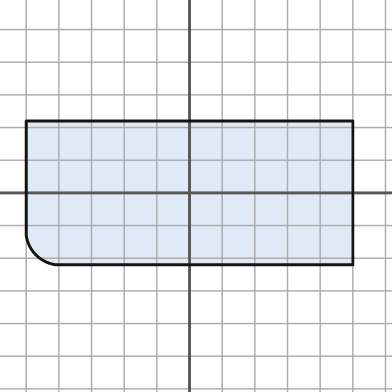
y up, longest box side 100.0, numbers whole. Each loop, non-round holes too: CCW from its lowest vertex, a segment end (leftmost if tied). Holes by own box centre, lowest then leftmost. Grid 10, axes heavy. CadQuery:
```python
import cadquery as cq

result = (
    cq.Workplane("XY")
    .moveTo(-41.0, -22.0)
    .lineTo(50.0, -22.0)
    .lineTo(50.0, 22.0)
    .lineTo(-50.0, 22.0)
    .lineTo(-50.0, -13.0)
    .threePointArc((-47.0, -19.0), (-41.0, -22.0))
    .close()
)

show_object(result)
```